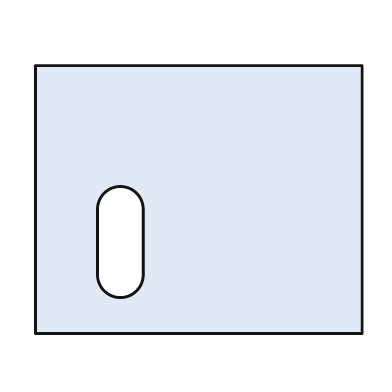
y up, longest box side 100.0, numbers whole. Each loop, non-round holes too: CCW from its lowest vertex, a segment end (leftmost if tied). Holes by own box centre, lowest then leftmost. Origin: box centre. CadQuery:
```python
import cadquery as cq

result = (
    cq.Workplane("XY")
    .moveTo(-50.0, -41.0)
    .lineTo(50.0, -41.0)
    .lineTo(50.0, 41.0)
    .lineTo(-50.0, 41.0)
    .close()
    .moveTo(-31.0, -23.0)
    .threePointArc((-24.0, -30.0), (-17.0, -23.0))
    .lineTo(-17.0, -3.0)
    .threePointArc((-24.0, 4.0), (-31.0, -3.0))
    .close()
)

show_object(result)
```